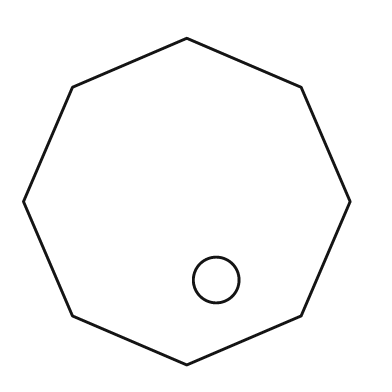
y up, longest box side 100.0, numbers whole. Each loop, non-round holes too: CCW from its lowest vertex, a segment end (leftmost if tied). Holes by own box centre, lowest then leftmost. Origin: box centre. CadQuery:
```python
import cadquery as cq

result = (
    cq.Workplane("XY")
    .moveTo(0.0, -50.0)
    .lineTo(35.0, -35.0)
    .lineTo(50.0, 0.0)
    .lineTo(35.0, 35.0)
    .lineTo(0.0, 50.0)
    .lineTo(-35.0, 35.0)
    .lineTo(-50.0, 0.0)
    .lineTo(-35.0, -35.0)
    .close()
    .moveTo(9.0, -24.0)
    .circle(7.0)
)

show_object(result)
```